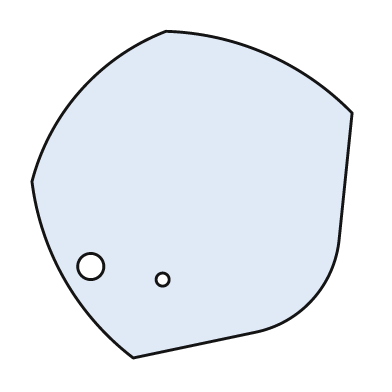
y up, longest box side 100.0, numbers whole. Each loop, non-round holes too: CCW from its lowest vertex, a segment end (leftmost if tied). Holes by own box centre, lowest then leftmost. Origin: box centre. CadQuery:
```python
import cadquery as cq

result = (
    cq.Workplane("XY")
    .moveTo(-18.0, -50.0)
    .lineTo(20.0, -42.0)
    .threePointArc((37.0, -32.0), (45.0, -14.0))
    .lineTo(49.0, 25.0)
    .threePointArc((23.0, 43.0), (-8.0, 50.0))
    .threePointArc((-34.0, 32.0), (-49.0, 4.0))
    .threePointArc((-39.0, -26.0), (-18.0, -50.0))
    .close()
    .moveTo(-9.0, -26.0)
    .circle(2.0)
    .moveTo(-31.0, -22.0)
    .circle(4.0)
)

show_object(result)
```